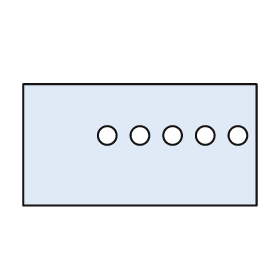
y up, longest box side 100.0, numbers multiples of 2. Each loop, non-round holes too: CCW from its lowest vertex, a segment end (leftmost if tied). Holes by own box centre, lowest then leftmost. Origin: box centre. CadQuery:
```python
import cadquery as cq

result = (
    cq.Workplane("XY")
    .moveTo(-50.0, -26.0)
    .lineTo(50.0, -26.0)
    .lineTo(50.0, 26.0)
    .lineTo(-50.0, 26.0)
    .close()
    .moveTo(-14.0, 4.0)
    .circle(4.0)
    .moveTo(0.0, 4.0)
    .circle(4.0)
    .moveTo(14.0, 4.0)
    .circle(4.0)
    .moveTo(28.0, 4.0)
    .circle(4.0)
    .moveTo(42.0, 4.0)
    .circle(4.0)
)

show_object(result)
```